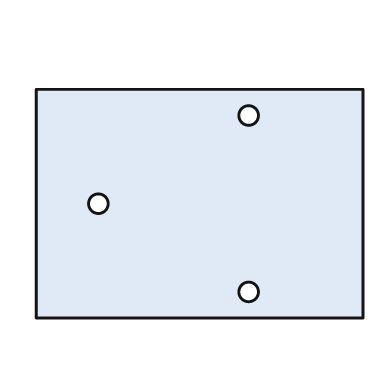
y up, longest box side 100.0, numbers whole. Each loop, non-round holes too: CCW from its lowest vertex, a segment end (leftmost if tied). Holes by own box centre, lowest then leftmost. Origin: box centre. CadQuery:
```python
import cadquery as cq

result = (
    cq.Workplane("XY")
    .moveTo(-50.0, -35.0)
    .lineTo(50.0, -35.0)
    .lineTo(50.0, 35.0)
    .lineTo(-50.0, 35.0)
    .close()
    .moveTo(15.0, -27.0)
    .circle(3.0)
    .moveTo(-31.0, 0.0)
    .circle(3.0)
    .moveTo(15.0, 27.0)
    .circle(3.0)
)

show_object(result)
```